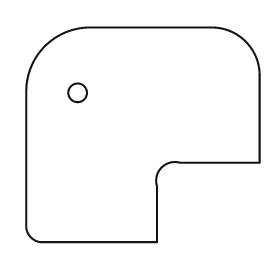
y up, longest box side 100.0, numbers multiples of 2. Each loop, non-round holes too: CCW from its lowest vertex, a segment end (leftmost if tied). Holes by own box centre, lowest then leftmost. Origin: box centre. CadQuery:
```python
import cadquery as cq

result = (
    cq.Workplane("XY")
    .moveTo(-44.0, -46.0)
    .lineTo(6.0, -46.0)
    .lineTo(6.0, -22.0)
    .threePointArc((8.0, -14.0), (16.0, -12.0))
    .lineTo(50.0, -12.0)
    .lineTo(50.0, 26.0)
    .threePointArc((44.0, 40.0), (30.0, 46.0))
    .lineTo(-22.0, 46.0)
    .threePointArc((-42.0, 38.0), (-50.0, 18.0))
    .lineTo(-50.0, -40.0)
    .threePointArc((-48.0, -44.0), (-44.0, -46.0))
    .close()
    .moveTo(-28.0, 18.0)
    .circle(4.0)
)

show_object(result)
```